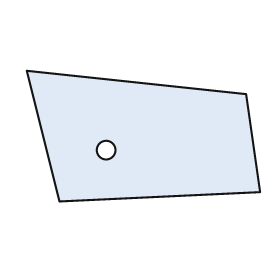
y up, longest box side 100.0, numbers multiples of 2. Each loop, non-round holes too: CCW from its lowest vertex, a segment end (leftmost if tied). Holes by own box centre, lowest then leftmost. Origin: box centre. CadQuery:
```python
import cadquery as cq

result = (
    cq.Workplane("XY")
    .moveTo(-36.0, -28.0)
    .lineTo(50.0, -24.0)
    .lineTo(44.0, 18.0)
    .lineTo(-50.0, 28.0)
    .close()
    .moveTo(-16.0, -6.0)
    .circle(4.0)
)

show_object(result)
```